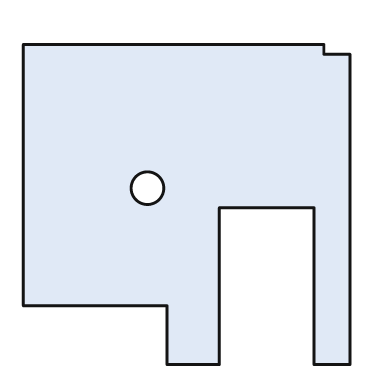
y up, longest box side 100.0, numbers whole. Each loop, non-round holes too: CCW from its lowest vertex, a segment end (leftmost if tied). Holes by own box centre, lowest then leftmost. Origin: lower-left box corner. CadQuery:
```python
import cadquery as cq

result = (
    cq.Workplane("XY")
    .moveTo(44.0, 0.0)
    .lineTo(60.0, 0.0)
    .lineTo(60.0, 48.0)
    .lineTo(89.0, 48.0)
    .lineTo(89.0, 0.0)
    .lineTo(100.0, 0.0)
    .lineTo(100.0, 95.0)
    .lineTo(92.0, 95.0)
    .lineTo(92.0, 98.0)
    .lineTo(0.0, 98.0)
    .lineTo(0.0, 18.0)
    .lineTo(44.0, 18.0)
    .close()
    .moveTo(38.0, 54.0)
    .circle(5.0)
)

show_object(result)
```